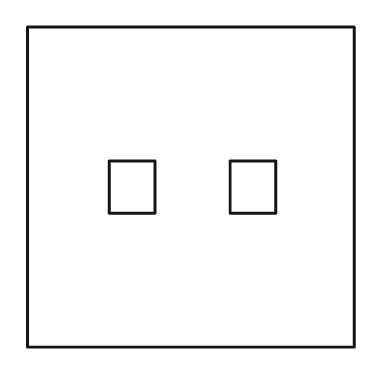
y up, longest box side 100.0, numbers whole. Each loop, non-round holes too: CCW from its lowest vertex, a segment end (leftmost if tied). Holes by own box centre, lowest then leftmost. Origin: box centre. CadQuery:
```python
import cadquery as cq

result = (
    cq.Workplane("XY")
    .moveTo(-50.0, -49.0)
    .lineTo(50.0, -49.0)
    .lineTo(50.0, 49.0)
    .lineTo(-50.0, 49.0)
    .close()
    .moveTo(-25.0, -8.0)
    .lineTo(-11.0, -8.0)
    .lineTo(-11.0, 8.0)
    .lineTo(-25.0, 8.0)
    .close()
    .moveTo(12.0, -8.0)
    .lineTo(26.0, -8.0)
    .lineTo(26.0, 8.0)
    .lineTo(12.0, 8.0)
    .close()
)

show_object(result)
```